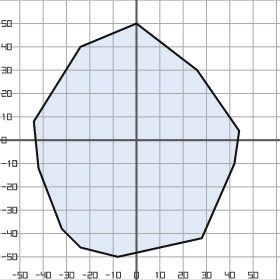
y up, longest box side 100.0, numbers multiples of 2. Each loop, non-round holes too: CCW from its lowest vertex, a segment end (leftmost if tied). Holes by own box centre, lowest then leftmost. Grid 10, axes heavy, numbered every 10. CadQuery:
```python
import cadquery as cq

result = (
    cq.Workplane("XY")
    .moveTo(-8.0, -50.0)
    .lineTo(28.0, -42.0)
    .lineTo(42.0, -10.0)
    .lineTo(44.0, 4.0)
    .lineTo(26.0, 30.0)
    .lineTo(0.0, 50.0)
    .lineTo(-24.0, 40.0)
    .lineTo(-44.0, 8.0)
    .lineTo(-42.0, -12.0)
    .lineTo(-32.0, -38.0)
    .lineTo(-24.0, -46.0)
    .close()
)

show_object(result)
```